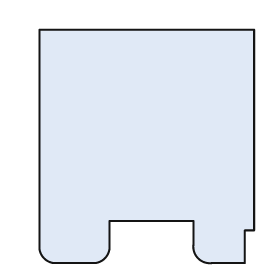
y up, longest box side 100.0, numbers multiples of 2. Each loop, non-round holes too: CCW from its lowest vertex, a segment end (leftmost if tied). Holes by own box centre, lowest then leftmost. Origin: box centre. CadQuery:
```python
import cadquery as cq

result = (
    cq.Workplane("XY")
    .moveTo(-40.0, -50.0)
    .lineTo(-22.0, -50.0)
    .threePointArc((-18.0, -48.0), (-16.0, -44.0))
    .lineTo(-16.0, -32.0)
    .lineTo(20.0, -32.0)
    .lineTo(20.0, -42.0)
    .threePointArc((22.0, -48.0), (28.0, -50.0))
    .lineTo(42.0, -50.0)
    .lineTo(42.0, -36.0)
    .lineTo(46.0, -36.0)
    .lineTo(46.0, 50.0)
    .lineTo(-46.0, 50.0)
    .lineTo(-46.0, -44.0)
    .threePointArc((-44.0, -48.0), (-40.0, -50.0))
    .close()
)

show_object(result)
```